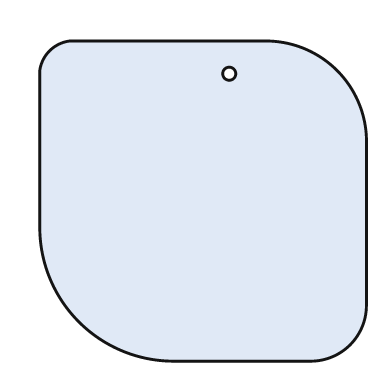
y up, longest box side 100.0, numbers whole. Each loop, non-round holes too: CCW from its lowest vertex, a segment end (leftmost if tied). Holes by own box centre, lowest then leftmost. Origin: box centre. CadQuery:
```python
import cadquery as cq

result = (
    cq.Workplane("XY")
    .moveTo(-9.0, -49.0)
    .lineTo(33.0, -49.0)
    .threePointArc((45.0, -44.0), (50.0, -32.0))
    .lineTo(50.0, 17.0)
    .threePointArc((41.0, 40.0), (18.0, 49.0))
    .lineTo(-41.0, 49.0)
    .threePointArc((-47.0, 46.0), (-50.0, 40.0))
    .lineTo(-50.0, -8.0)
    .threePointArc((-38.0, -37.0), (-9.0, -49.0))
    .close()
    .moveTo(8.0, 39.0)
    .circle(2.0)
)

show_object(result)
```